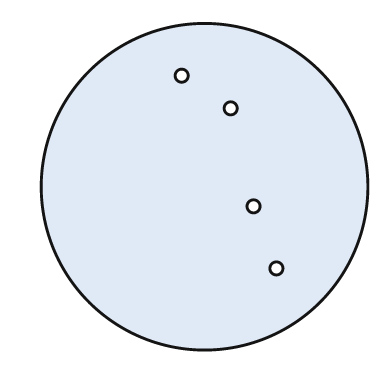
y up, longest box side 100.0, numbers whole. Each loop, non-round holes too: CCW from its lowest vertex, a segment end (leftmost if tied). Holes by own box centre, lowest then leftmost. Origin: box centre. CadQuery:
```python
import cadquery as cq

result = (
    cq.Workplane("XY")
    .moveTo(0.0, 0.0)
    .circle(50.0)
    .moveTo(22.0, -25.0)
    .circle(2.0)
    .moveTo(15.0, -6.0)
    .circle(2.0)
    .moveTo(8.0, 24.0)
    .circle(2.0)
    .moveTo(-7.0, 34.0)
    .circle(2.0)
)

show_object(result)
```